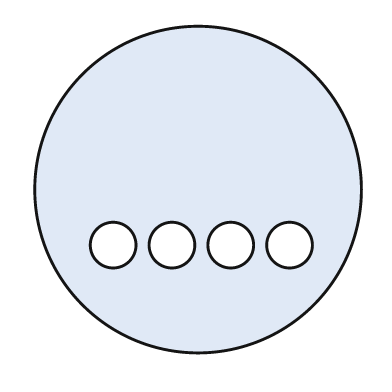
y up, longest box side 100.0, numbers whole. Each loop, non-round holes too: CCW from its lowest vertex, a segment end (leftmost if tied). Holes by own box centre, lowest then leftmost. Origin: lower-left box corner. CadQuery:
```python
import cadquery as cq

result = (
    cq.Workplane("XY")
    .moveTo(50.0, 50.0)
    .circle(50.0)
    .moveTo(24.0, 33.0)
    .circle(7.0)
    .moveTo(42.0, 33.0)
    .circle(7.0)
    .moveTo(60.0, 33.0)
    .circle(7.0)
    .moveTo(78.0, 33.0)
    .circle(7.0)
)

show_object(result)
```